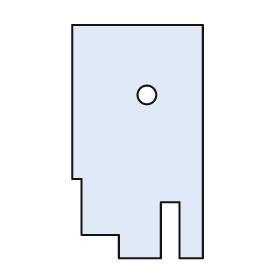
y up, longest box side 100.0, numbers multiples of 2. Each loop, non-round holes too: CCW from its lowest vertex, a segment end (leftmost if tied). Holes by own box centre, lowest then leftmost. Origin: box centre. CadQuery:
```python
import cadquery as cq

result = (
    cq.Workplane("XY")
    .moveTo(-8.0, -50.0)
    .lineTo(10.0, -50.0)
    .lineTo(10.0, -26.0)
    .lineTo(18.0, -26.0)
    .lineTo(18.0, -50.0)
    .lineTo(28.0, -50.0)
    .lineTo(28.0, 50.0)
    .lineTo(-28.0, 50.0)
    .lineTo(-28.0, -16.0)
    .lineTo(-24.0, -16.0)
    .lineTo(-24.0, -40.0)
    .lineTo(-8.0, -40.0)
    .close()
    .moveTo(4.0, 20.0)
    .circle(4.0)
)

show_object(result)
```